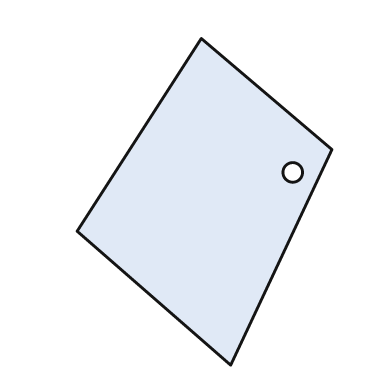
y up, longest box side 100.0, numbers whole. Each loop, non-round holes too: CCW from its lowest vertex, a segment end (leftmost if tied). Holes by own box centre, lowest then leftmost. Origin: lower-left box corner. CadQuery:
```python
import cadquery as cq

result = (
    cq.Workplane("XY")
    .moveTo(47.0, 0.0)
    .lineTo(78.0, 66.0)
    .lineTo(38.0, 100.0)
    .lineTo(0.0, 41.0)
    .close()
    .moveTo(66.0, 59.0)
    .circle(3.0)
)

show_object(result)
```